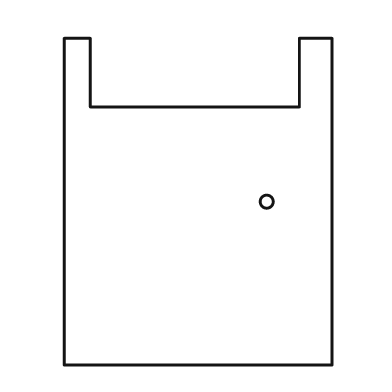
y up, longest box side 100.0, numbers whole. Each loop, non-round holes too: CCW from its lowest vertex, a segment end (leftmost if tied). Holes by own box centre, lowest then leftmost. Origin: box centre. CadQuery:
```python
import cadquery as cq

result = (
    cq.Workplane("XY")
    .moveTo(-41.0, -50.0)
    .lineTo(41.0, -50.0)
    .lineTo(41.0, 50.0)
    .lineTo(31.0, 50.0)
    .lineTo(31.0, 29.0)
    .lineTo(-33.0, 29.0)
    .lineTo(-33.0, 50.0)
    .lineTo(-41.0, 50.0)
    .close()
    .moveTo(21.0, 0.0)
    .circle(2.0)
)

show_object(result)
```